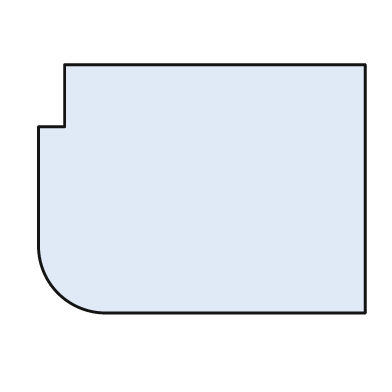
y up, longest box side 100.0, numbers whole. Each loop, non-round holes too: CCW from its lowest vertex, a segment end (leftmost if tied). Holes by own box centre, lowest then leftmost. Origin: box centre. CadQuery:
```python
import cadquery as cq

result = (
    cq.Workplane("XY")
    .moveTo(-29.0, -38.0)
    .lineTo(50.0, -38.0)
    .lineTo(50.0, 38.0)
    .lineTo(-42.0, 38.0)
    .lineTo(-42.0, 19.0)
    .lineTo(-50.0, 19.0)
    .lineTo(-50.0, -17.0)
    .threePointArc((-44.0, -32.0), (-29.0, -38.0))
    .close()
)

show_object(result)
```